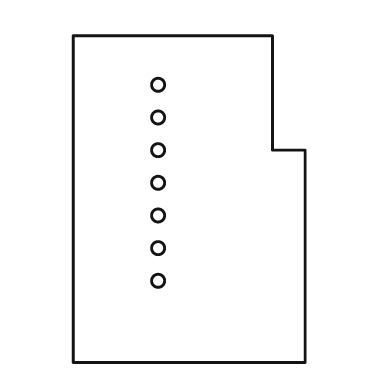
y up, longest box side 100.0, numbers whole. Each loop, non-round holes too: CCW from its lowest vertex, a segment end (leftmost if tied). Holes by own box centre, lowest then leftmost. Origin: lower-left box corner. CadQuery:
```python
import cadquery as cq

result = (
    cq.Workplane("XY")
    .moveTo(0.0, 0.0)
    .lineTo(71.0, 0.0)
    .lineTo(71.0, 65.0)
    .lineTo(61.0, 65.0)
    .lineTo(61.0, 100.0)
    .lineTo(0.0, 100.0)
    .close()
    .moveTo(26.0, 25.0)
    .circle(2.0)
    .moveTo(26.0, 35.0)
    .circle(2.0)
    .moveTo(26.0, 45.0)
    .circle(2.0)
    .moveTo(26.0, 55.0)
    .circle(2.0)
    .moveTo(26.0, 65.0)
    .circle(2.0)
    .moveTo(26.0, 75.0)
    .circle(2.0)
    .moveTo(26.0, 85.0)
    .circle(2.0)
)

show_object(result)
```